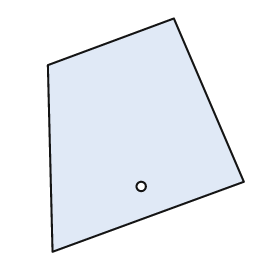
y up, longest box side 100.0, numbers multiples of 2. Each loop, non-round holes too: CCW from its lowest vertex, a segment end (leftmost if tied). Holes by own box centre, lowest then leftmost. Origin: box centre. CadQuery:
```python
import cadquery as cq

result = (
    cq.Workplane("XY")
    .moveTo(-40.0, -50.0)
    .lineTo(42.0, -20.0)
    .lineTo(12.0, 50.0)
    .lineTo(-42.0, 30.0)
    .close()
    .moveTo(-2.0, -22.0)
    .circle(2.0)
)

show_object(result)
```